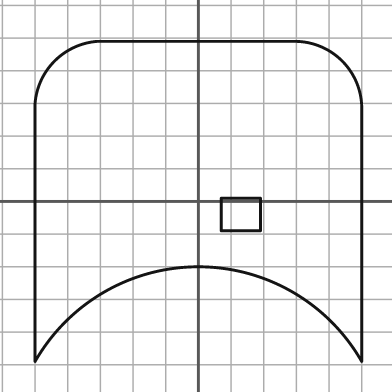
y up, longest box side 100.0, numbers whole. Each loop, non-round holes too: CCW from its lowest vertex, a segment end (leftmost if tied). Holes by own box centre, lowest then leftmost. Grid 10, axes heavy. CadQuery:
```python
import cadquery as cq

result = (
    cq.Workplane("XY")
    .moveTo(-50.0, -49.0)
    .threePointArc((0.0, -20.0), (50.0, -49.0))
    .lineTo(50.0, 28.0)
    .threePointArc((44.0, 43.0), (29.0, 49.0))
    .lineTo(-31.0, 49.0)
    .threePointArc((-44.0, 43.0), (-50.0, 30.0))
    .close()
    .moveTo(7.0, -9.0)
    .lineTo(19.0, -9.0)
    .lineTo(19.0, 1.0)
    .lineTo(7.0, 1.0)
    .close()
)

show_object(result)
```